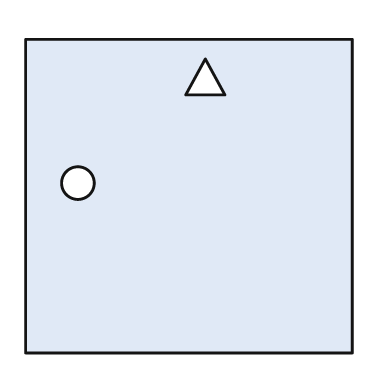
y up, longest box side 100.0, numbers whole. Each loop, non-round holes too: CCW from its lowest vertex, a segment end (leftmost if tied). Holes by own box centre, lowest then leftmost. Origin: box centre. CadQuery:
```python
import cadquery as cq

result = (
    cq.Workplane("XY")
    .moveTo(-50.0, -48.0)
    .lineTo(50.0, -48.0)
    .lineTo(50.0, 48.0)
    .lineTo(-50.0, 48.0)
    .close()
    .moveTo(-34.0, 4.0)
    .circle(5.0)
    .moveTo(-1.0, 31.0)
    .lineTo(11.0, 31.0)
    .lineTo(5.0, 42.0)
    .close()
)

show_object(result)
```